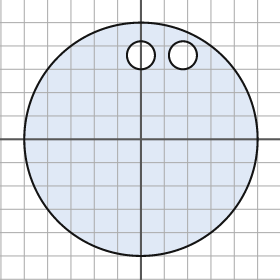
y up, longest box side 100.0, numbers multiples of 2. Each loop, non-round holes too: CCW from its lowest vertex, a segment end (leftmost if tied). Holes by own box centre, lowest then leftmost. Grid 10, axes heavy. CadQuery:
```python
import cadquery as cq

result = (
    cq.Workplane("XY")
    .moveTo(0.0, 0.0)
    .circle(50.0)
    .moveTo(0.0, 36.0)
    .circle(6.0)
    .moveTo(18.0, 36.0)
    .circle(6.0)
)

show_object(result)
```